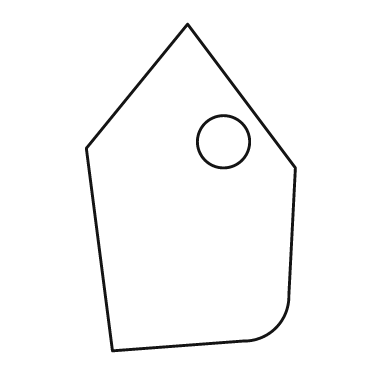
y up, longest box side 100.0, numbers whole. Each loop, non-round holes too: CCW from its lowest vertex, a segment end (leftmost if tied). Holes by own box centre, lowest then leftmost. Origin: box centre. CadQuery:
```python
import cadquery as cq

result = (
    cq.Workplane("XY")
    .moveTo(-24.0, -50.0)
    .lineTo(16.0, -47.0)
    .threePointArc((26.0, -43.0), (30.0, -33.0))
    .lineTo(32.0, 6.0)
    .lineTo(-1.0, 50.0)
    .lineTo(-32.0, 12.0)
    .close()
    .moveTo(10.0, 14.0)
    .circle(8.0)
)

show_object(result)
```